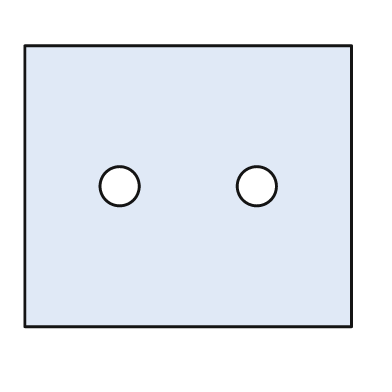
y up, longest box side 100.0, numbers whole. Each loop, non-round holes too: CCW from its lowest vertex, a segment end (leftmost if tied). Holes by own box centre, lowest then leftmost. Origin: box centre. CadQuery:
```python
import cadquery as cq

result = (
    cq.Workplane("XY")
    .moveTo(-50.0, -43.0)
    .lineTo(50.0, -43.0)
    .lineTo(50.0, 43.0)
    .lineTo(-50.0, 43.0)
    .close()
    .moveTo(-21.0, 0.0)
    .circle(6.0)
    .moveTo(21.0, 0.0)
    .circle(6.0)
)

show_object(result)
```